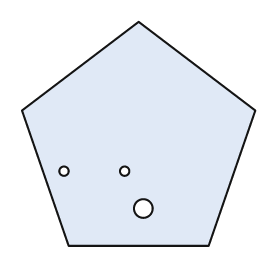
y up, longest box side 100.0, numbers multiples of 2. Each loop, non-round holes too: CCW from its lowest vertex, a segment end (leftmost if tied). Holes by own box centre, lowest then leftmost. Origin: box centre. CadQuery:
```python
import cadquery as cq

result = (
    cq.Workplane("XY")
    .moveTo(-30.0, -48.0)
    .lineTo(30.0, -48.0)
    .lineTo(50.0, 10.0)
    .lineTo(0.0, 48.0)
    .lineTo(-50.0, 10.0)
    .close()
    .moveTo(2.0, -32.0)
    .circle(4.0)
    .moveTo(-32.0, -16.0)
    .circle(2.0)
    .moveTo(-6.0, -16.0)
    .circle(2.0)
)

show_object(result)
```